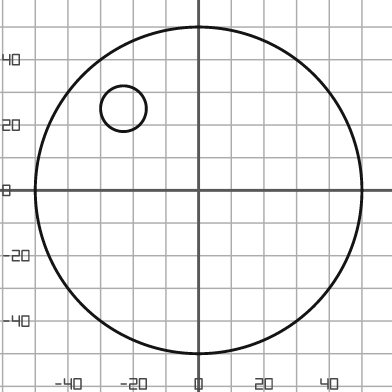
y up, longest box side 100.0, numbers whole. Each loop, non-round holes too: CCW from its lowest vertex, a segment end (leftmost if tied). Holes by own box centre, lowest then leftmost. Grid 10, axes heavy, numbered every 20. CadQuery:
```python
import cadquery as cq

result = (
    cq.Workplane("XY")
    .moveTo(0.0, 0.0)
    .circle(50.0)
    .moveTo(-23.0, 25.0)
    .circle(7.0)
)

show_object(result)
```